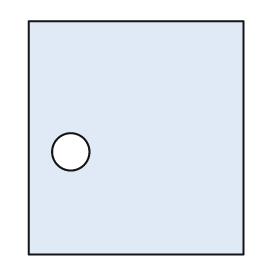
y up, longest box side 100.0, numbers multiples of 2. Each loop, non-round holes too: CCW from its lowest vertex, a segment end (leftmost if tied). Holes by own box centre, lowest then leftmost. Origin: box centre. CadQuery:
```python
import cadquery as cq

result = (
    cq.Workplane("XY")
    .moveTo(-46.0, -50.0)
    .lineTo(46.0, -50.0)
    .lineTo(46.0, 50.0)
    .lineTo(-46.0, 50.0)
    .close()
    .moveTo(-28.0, -6.0)
    .circle(8.0)
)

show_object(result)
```